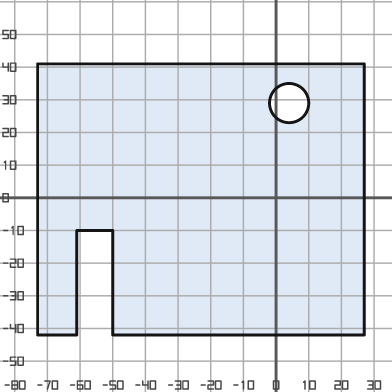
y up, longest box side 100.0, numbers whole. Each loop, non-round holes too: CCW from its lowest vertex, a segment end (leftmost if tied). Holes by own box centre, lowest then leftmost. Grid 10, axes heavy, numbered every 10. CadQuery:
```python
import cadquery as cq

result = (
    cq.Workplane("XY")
    .moveTo(-73.0, -42.0)
    .lineTo(-61.0, -42.0)
    .lineTo(-61.0, -10.0)
    .lineTo(-50.0, -10.0)
    .lineTo(-50.0, -42.0)
    .lineTo(27.0, -42.0)
    .lineTo(27.0, 41.0)
    .lineTo(-73.0, 41.0)
    .close()
    .moveTo(4.0, 29.0)
    .circle(6.0)
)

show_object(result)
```